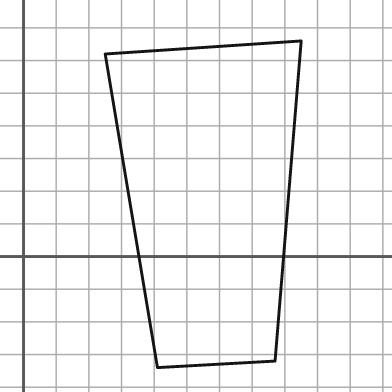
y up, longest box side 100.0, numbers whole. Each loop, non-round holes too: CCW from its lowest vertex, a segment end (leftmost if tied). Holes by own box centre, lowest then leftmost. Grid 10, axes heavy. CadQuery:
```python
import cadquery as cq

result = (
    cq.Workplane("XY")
    .moveTo(41.0, -34.0)
    .lineTo(77.0, -32.0)
    .lineTo(85.0, 66.0)
    .lineTo(25.0, 62.0)
    .close()
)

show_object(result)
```